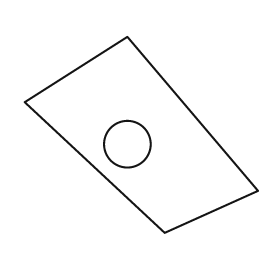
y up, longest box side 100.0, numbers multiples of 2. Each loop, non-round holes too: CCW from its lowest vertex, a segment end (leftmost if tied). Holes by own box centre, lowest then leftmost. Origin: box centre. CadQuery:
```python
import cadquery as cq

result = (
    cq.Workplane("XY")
    .moveTo(10.0, -42.0)
    .lineTo(50.0, -24.0)
    .lineTo(-6.0, 42.0)
    .lineTo(-50.0, 14.0)
    .close()
    .moveTo(-6.0, -4.0)
    .circle(10.0)
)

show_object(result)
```